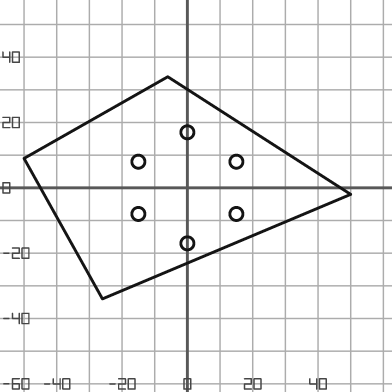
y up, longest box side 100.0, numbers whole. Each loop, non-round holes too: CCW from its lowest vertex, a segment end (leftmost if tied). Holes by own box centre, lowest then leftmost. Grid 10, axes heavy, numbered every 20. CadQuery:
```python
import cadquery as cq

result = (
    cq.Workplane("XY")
    .moveTo(-26.0, -34.0)
    .lineTo(50.0, -2.0)
    .lineTo(-6.0, 34.0)
    .lineTo(-50.0, 9.0)
    .close()
    .moveTo(0.0, -17.0)
    .circle(2.0)
    .moveTo(-15.0, -8.0)
    .circle(2.0)
    .moveTo(15.0, -8.0)
    .circle(2.0)
    .moveTo(-15.0, 8.0)
    .circle(2.0)
    .moveTo(15.0, 8.0)
    .circle(2.0)
    .moveTo(0.0, 17.0)
    .circle(2.0)
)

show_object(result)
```